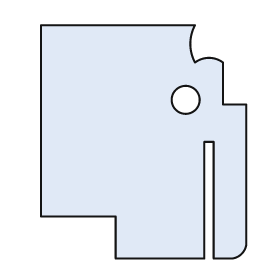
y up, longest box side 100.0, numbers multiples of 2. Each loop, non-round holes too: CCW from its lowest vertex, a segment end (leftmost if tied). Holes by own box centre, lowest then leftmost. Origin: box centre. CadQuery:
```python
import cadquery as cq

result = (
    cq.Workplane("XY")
    .moveTo(-12.0, -50.0)
    .lineTo(26.0, -50.0)
    .lineTo(26.0, 0.0)
    .lineTo(30.0, 0.0)
    .lineTo(30.0, -50.0)
    .lineTo(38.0, -50.0)
    .threePointArc((42.0, -48.0), (44.0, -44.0))
    .lineTo(44.0, 16.0)
    .lineTo(34.0, 16.0)
    .lineTo(34.0, 34.0)
    .threePointArc((28.0, 36.0), (22.0, 34.0))
    .threePointArc((20.0, 42.0), (22.0, 50.0))
    .lineTo(-44.0, 50.0)
    .lineTo(-44.0, -32.0)
    .lineTo(-12.0, -32.0)
    .close()
    .moveTo(18.0, 18.0)
    .circle(6.0)
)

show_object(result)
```